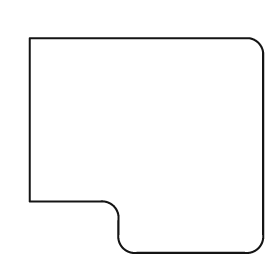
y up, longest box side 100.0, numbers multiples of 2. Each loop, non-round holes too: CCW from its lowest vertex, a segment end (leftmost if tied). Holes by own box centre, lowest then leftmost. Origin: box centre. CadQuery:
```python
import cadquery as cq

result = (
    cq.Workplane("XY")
    .moveTo(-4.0, -46.0)
    .lineTo(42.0, -46.0)
    .threePointArc((48.0, -44.0), (50.0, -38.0))
    .lineTo(50.0, 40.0)
    .threePointArc((48.0, 44.0), (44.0, 46.0))
    .lineTo(-50.0, 46.0)
    .lineTo(-50.0, -24.0)
    .lineTo(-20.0, -24.0)
    .threePointArc((-14.0, -26.0), (-12.0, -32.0))
    .lineTo(-12.0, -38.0)
    .threePointArc((-10.0, -44.0), (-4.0, -46.0))
    .close()
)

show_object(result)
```